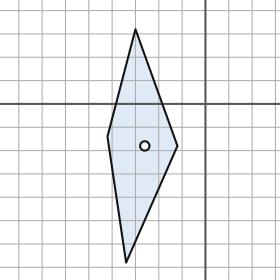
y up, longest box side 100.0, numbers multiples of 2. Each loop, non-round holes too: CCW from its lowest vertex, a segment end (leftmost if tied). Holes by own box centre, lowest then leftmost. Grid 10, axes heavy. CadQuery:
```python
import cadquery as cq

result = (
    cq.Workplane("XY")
    .moveTo(-34.0, -68.0)
    .lineTo(-12.0, -18.0)
    .lineTo(-30.0, 32.0)
    .lineTo(-42.0, -14.0)
    .close()
    .moveTo(-26.0, -18.0)
    .circle(2.0)
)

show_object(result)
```